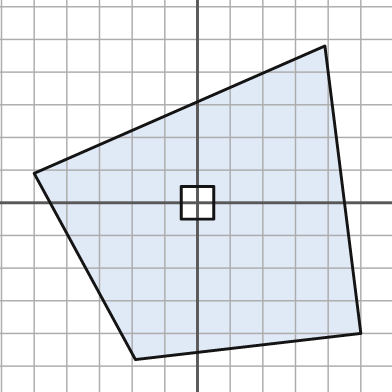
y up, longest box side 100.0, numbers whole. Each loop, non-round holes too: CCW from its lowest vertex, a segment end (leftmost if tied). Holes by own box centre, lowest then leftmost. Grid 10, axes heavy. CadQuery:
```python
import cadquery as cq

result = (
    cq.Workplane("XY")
    .moveTo(-19.0, -48.0)
    .lineTo(50.0, -40.0)
    .lineTo(39.0, 48.0)
    .lineTo(-50.0, 9.0)
    .close()
    .moveTo(-5.0, -5.0)
    .lineTo(5.0, -5.0)
    .lineTo(5.0, 5.0)
    .lineTo(-5.0, 5.0)
    .close()
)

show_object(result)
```